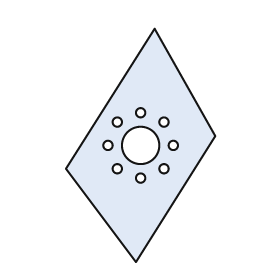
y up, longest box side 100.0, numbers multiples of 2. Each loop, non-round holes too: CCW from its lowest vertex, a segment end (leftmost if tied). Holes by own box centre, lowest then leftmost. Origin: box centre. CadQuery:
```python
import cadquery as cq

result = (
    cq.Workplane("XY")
    .moveTo(-2.0, -50.0)
    .lineTo(32.0, 4.0)
    .lineTo(6.0, 50.0)
    .lineTo(-32.0, -10.0)
    .close()
    .moveTo(0.0, -14.0)
    .circle(2.0)
    .moveTo(-10.0, -10.0)
    .circle(2.0)
    .moveTo(10.0, -10.0)
    .circle(2.0)
    .moveTo(-14.0, 0.0)
    .circle(2.0)
    .moveTo(0.0, 0.0)
    .circle(8.0)
    .moveTo(14.0, 0.0)
    .circle(2.0)
    .moveTo(-10.0, 10.0)
    .circle(2.0)
    .moveTo(10.0, 10.0)
    .circle(2.0)
    .moveTo(0.0, 14.0)
    .circle(2.0)
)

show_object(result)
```